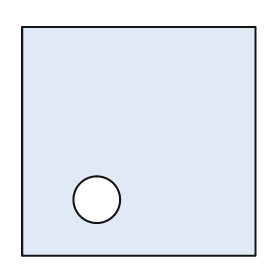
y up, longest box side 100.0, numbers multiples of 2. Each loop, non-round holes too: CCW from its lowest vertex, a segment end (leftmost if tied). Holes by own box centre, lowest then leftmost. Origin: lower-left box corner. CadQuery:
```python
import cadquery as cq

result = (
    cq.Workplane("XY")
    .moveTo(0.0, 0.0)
    .lineTo(100.0, 0.0)
    .lineTo(100.0, 98.0)
    .lineTo(0.0, 98.0)
    .close()
    .moveTo(32.0, 24.0)
    .circle(10.0)
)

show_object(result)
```